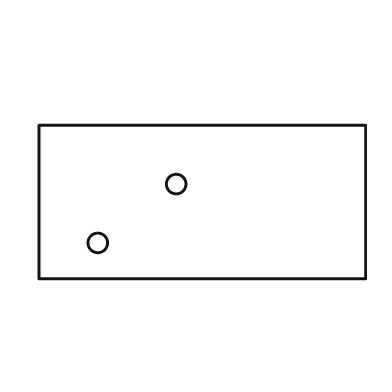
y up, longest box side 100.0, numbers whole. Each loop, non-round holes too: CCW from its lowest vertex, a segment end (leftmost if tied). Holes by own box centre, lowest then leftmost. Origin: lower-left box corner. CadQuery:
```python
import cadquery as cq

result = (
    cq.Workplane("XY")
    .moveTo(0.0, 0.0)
    .lineTo(100.0, 0.0)
    .lineTo(100.0, 47.0)
    .lineTo(0.0, 47.0)
    .close()
    .moveTo(18.0, 11.0)
    .circle(3.0)
    .moveTo(42.0, 29.0)
    .circle(3.0)
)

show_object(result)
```